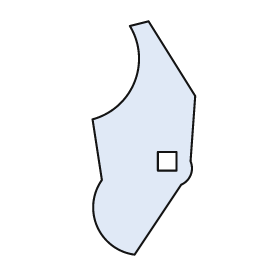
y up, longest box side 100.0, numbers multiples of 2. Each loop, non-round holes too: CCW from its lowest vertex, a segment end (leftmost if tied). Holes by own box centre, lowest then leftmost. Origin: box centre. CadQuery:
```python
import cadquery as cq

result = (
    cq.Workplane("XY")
    .moveTo(-4.0, -50.0)
    .lineTo(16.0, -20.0)
    .threePointArc((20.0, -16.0), (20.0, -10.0))
    .lineTo(22.0, 18.0)
    .lineTo(2.0, 50.0)
    .lineTo(-6.0, 48.0)
    .threePointArc((-4.0, 24.0), (-22.0, 8.0))
    .lineTo(-18.0, -18.0)
    .threePointArc((-20.0, -38.0), (-4.0, -50.0))
    .close()
    .moveTo(6.0, -14.0)
    .lineTo(14.0, -14.0)
    .lineTo(14.0, -6.0)
    .lineTo(6.0, -6.0)
    .close()
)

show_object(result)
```